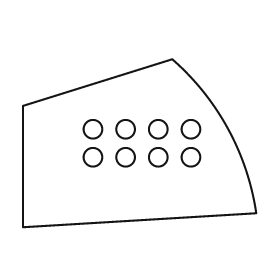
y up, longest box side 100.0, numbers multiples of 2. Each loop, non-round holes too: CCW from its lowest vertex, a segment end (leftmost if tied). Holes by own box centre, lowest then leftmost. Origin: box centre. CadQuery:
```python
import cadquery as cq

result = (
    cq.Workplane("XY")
    .moveTo(-50.0, -36.0)
    .lineTo(50.0, -30.0)
    .threePointArc((38.0, 6.0), (14.0, 36.0))
    .lineTo(-50.0, 16.0)
    .close()
    .moveTo(-20.0, -6.0)
    .circle(4.0)
    .moveTo(-6.0, -6.0)
    .circle(4.0)
    .moveTo(8.0, -6.0)
    .circle(4.0)
    .moveTo(22.0, -6.0)
    .circle(4.0)
    .moveTo(-20.0, 6.0)
    .circle(4.0)
    .moveTo(-6.0, 6.0)
    .circle(4.0)
    .moveTo(8.0, 6.0)
    .circle(4.0)
    .moveTo(22.0, 6.0)
    .circle(4.0)
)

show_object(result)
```